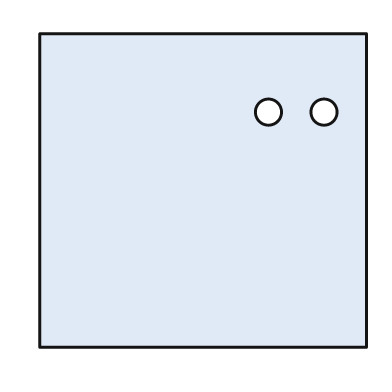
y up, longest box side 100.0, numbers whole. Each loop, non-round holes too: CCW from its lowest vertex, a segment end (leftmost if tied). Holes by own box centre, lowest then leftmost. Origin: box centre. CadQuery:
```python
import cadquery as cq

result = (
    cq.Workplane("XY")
    .moveTo(-50.0, -48.0)
    .lineTo(50.0, -48.0)
    .lineTo(50.0, 48.0)
    .lineTo(-50.0, 48.0)
    .close()
    .moveTo(20.0, 24.0)
    .circle(4.0)
    .moveTo(37.0, 24.0)
    .circle(4.0)
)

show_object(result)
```